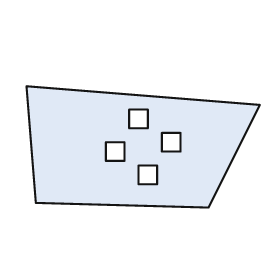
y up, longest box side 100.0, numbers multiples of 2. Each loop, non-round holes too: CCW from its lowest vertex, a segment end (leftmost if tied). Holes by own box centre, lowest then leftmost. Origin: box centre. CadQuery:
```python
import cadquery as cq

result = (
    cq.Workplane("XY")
    .moveTo(28.0, -26.0)
    .lineTo(50.0, 18.0)
    .lineTo(-50.0, 26.0)
    .lineTo(-46.0, -24.0)
    .close()
    .moveTo(-2.0, -16.0)
    .lineTo(6.0, -16.0)
    .lineTo(6.0, -8.0)
    .lineTo(-2.0, -8.0)
    .close()
    .moveTo(-16.0, -6.0)
    .lineTo(-8.0, -6.0)
    .lineTo(-8.0, 2.0)
    .lineTo(-16.0, 2.0)
    .close()
    .moveTo(8.0, -2.0)
    .lineTo(16.0, -2.0)
    .lineTo(16.0, 6.0)
    .lineTo(8.0, 6.0)
    .close()
    .moveTo(-6.0, 8.0)
    .lineTo(2.0, 8.0)
    .lineTo(2.0, 16.0)
    .lineTo(-6.0, 16.0)
    .close()
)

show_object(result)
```